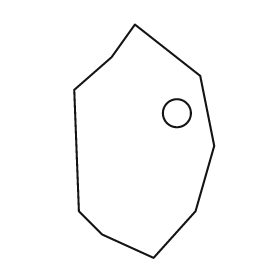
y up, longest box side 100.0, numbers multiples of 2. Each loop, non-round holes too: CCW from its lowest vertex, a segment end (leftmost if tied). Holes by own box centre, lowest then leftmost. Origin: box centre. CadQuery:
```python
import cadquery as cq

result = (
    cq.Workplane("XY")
    .moveTo(4.0, -50.0)
    .lineTo(22.0, -30.0)
    .lineTo(30.0, -2.0)
    .lineTo(24.0, 28.0)
    .lineTo(-4.0, 50.0)
    .lineTo(-14.0, 36.0)
    .lineTo(-30.0, 22.0)
    .lineTo(-28.0, -30.0)
    .lineTo(-18.0, -40.0)
    .close()
    .moveTo(14.0, 12.0)
    .circle(6.0)
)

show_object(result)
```